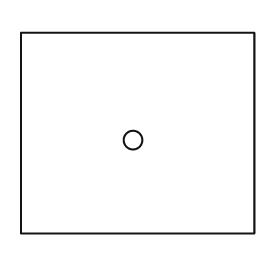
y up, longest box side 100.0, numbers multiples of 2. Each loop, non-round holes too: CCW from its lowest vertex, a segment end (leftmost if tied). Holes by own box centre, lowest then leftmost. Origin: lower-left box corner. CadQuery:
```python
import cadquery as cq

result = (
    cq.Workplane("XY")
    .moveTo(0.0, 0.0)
    .lineTo(100.0, 0.0)
    .lineTo(100.0, 86.0)
    .lineTo(0.0, 86.0)
    .close()
    .moveTo(48.0, 40.0)
    .circle(4.0)
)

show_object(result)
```